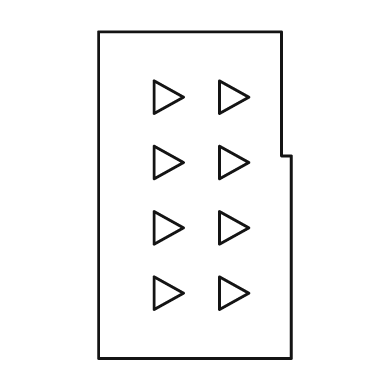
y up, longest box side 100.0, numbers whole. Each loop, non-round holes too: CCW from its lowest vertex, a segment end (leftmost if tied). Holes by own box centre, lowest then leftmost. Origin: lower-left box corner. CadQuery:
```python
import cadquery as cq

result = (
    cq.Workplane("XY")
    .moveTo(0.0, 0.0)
    .lineTo(59.0, 0.0)
    .lineTo(59.0, 62.0)
    .lineTo(56.0, 62.0)
    .lineTo(56.0, 100.0)
    .lineTo(0.0, 100.0)
    .close()
    .moveTo(17.0, 15.0)
    .lineTo(26.0, 20.0)
    .lineTo(17.0, 25.0)
    .close()
    .moveTo(37.0, 15.0)
    .lineTo(46.0, 20.0)
    .lineTo(37.0, 25.0)
    .close()
    .moveTo(17.0, 35.0)
    .lineTo(26.0, 40.0)
    .lineTo(17.0, 45.0)
    .close()
    .moveTo(37.0, 35.0)
    .lineTo(46.0, 40.0)
    .lineTo(37.0, 45.0)
    .close()
    .moveTo(17.0, 55.0)
    .lineTo(26.0, 60.0)
    .lineTo(17.0, 65.0)
    .close()
    .moveTo(37.0, 55.0)
    .lineTo(46.0, 60.0)
    .lineTo(37.0, 65.0)
    .close()
    .moveTo(17.0, 75.0)
    .lineTo(26.0, 80.0)
    .lineTo(17.0, 85.0)
    .close()
    .moveTo(37.0, 75.0)
    .lineTo(46.0, 80.0)
    .lineTo(37.0, 85.0)
    .close()
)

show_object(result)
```